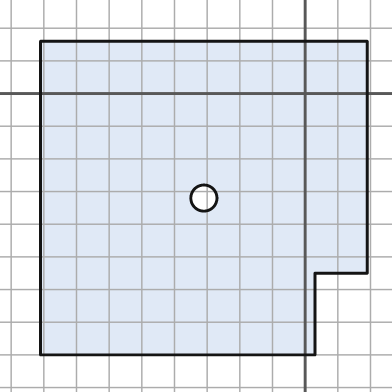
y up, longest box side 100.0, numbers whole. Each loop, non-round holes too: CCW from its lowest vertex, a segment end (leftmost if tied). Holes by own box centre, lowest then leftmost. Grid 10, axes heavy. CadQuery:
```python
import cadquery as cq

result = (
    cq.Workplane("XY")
    .moveTo(-81.0, -80.0)
    .lineTo(3.0, -80.0)
    .lineTo(3.0, -55.0)
    .lineTo(19.0, -55.0)
    .lineTo(19.0, 16.0)
    .lineTo(-81.0, 16.0)
    .close()
    .moveTo(-31.0, -32.0)
    .circle(4.0)
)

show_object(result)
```